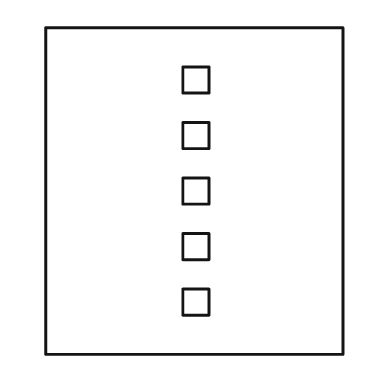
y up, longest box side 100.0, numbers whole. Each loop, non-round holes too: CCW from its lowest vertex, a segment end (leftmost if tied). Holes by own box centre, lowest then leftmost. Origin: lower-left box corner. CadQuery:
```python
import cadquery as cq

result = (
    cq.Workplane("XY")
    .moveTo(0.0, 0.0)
    .lineTo(91.0, 0.0)
    .lineTo(91.0, 100.0)
    .lineTo(0.0, 100.0)
    .close()
    .moveTo(42.0, 12.0)
    .lineTo(50.0, 12.0)
    .lineTo(50.0, 20.0)
    .lineTo(42.0, 20.0)
    .close()
    .moveTo(42.0, 29.0)
    .lineTo(50.0, 29.0)
    .lineTo(50.0, 37.0)
    .lineTo(42.0, 37.0)
    .close()
    .moveTo(42.0, 46.0)
    .lineTo(50.0, 46.0)
    .lineTo(50.0, 54.0)
    .lineTo(42.0, 54.0)
    .close()
    .moveTo(42.0, 63.0)
    .lineTo(50.0, 63.0)
    .lineTo(50.0, 71.0)
    .lineTo(42.0, 71.0)
    .close()
    .moveTo(42.0, 80.0)
    .lineTo(50.0, 80.0)
    .lineTo(50.0, 88.0)
    .lineTo(42.0, 88.0)
    .close()
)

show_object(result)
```